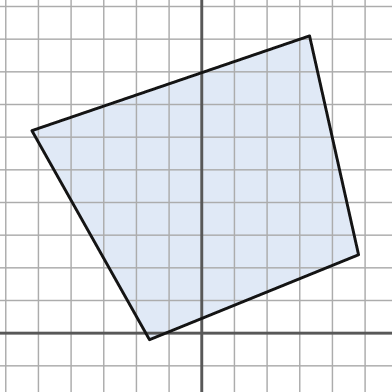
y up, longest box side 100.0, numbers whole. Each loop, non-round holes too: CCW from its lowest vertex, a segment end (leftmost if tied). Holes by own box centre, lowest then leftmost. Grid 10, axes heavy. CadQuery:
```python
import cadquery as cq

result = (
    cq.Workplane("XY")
    .moveTo(-16.0, -2.0)
    .lineTo(48.0, 24.0)
    .lineTo(33.0, 91.0)
    .lineTo(-52.0, 62.0)
    .close()
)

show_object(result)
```